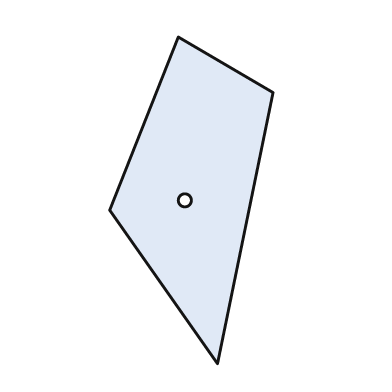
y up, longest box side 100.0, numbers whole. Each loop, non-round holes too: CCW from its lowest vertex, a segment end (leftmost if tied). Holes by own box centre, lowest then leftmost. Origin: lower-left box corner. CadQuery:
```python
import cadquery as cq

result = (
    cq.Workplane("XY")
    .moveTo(33.0, 0.0)
    .lineTo(50.0, 83.0)
    .lineTo(21.0, 100.0)
    .lineTo(0.0, 47.0)
    .close()
    .moveTo(23.0, 50.0)
    .circle(2.0)
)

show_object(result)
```